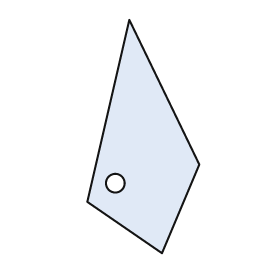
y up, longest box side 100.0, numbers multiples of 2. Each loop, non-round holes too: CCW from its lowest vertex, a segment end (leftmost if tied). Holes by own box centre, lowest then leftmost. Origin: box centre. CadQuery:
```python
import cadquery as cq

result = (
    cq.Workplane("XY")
    .moveTo(8.0, -50.0)
    .lineTo(24.0, -12.0)
    .lineTo(-6.0, 50.0)
    .lineTo(-24.0, -28.0)
    .close()
    .moveTo(-12.0, -20.0)
    .circle(4.0)
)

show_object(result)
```